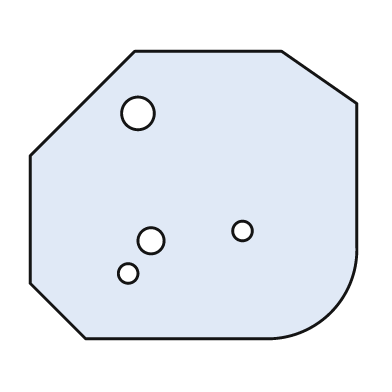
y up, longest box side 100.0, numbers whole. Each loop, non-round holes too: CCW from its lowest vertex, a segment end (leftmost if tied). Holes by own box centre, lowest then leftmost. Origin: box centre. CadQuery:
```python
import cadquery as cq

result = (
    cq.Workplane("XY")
    .moveTo(-33.0, -44.0)
    .lineTo(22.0, -44.0)
    .threePointArc((42.0, -36.0), (50.0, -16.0))
    .lineTo(50.0, 28.0)
    .lineTo(27.0, 44.0)
    .lineTo(-18.0, 44.0)
    .lineTo(-50.0, 12.0)
    .lineTo(-50.0, -27.0)
    .close()
    .moveTo(-20.0, -24.0)
    .circle(3.0)
    .moveTo(-13.0, -14.0)
    .circle(4.0)
    .moveTo(15.0, -11.0)
    .circle(3.0)
    .moveTo(-17.0, 25.0)
    .circle(5.0)
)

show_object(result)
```